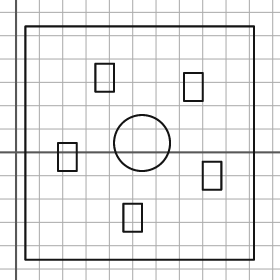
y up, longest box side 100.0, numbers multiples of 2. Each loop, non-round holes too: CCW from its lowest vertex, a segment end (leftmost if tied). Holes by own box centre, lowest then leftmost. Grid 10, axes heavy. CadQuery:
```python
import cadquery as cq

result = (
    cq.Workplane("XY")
    .moveTo(4.0, -46.0)
    .lineTo(102.0, -46.0)
    .lineTo(102.0, 54.0)
    .lineTo(4.0, 54.0)
    .close()
    .moveTo(46.0, -34.0)
    .lineTo(54.0, -34.0)
    .lineTo(54.0, -22.0)
    .lineTo(46.0, -22.0)
    .close()
    .moveTo(80.0, -16.0)
    .lineTo(88.0, -16.0)
    .lineTo(88.0, -4.0)
    .lineTo(80.0, -4.0)
    .close()
    .moveTo(18.0, -8.0)
    .lineTo(26.0, -8.0)
    .lineTo(26.0, 4.0)
    .lineTo(18.0, 4.0)
    .close()
    .moveTo(54.0, 4.0)
    .circle(12.0)
    .moveTo(72.0, 22.0)
    .lineTo(80.0, 22.0)
    .lineTo(80.0, 34.0)
    .lineTo(72.0, 34.0)
    .close()
    .moveTo(34.0, 26.0)
    .lineTo(42.0, 26.0)
    .lineTo(42.0, 38.0)
    .lineTo(34.0, 38.0)
    .close()
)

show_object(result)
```